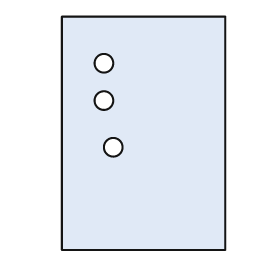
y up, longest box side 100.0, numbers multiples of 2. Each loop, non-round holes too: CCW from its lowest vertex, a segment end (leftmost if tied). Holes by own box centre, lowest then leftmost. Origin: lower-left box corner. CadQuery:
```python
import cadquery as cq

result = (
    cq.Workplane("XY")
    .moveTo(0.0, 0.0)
    .lineTo(70.0, 0.0)
    .lineTo(70.0, 100.0)
    .lineTo(0.0, 100.0)
    .close()
    .moveTo(22.0, 44.0)
    .circle(4.0)
    .moveTo(18.0, 64.0)
    .circle(4.0)
    .moveTo(18.0, 80.0)
    .circle(4.0)
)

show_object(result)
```